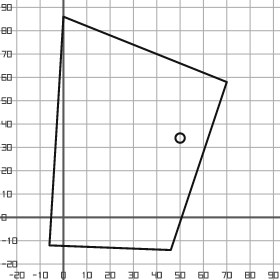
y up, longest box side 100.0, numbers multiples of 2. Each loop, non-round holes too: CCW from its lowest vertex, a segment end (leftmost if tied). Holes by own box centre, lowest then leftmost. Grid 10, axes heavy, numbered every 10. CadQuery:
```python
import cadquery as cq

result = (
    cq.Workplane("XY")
    .moveTo(46.0, -14.0)
    .lineTo(70.0, 58.0)
    .lineTo(0.0, 86.0)
    .lineTo(-6.0, -12.0)
    .close()
    .moveTo(50.0, 34.0)
    .circle(2.0)
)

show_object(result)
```